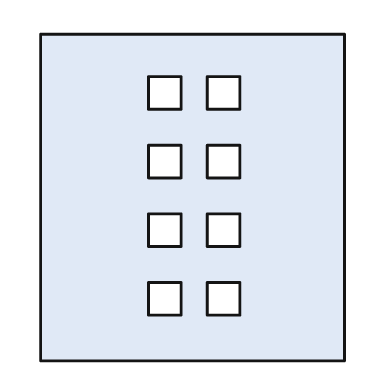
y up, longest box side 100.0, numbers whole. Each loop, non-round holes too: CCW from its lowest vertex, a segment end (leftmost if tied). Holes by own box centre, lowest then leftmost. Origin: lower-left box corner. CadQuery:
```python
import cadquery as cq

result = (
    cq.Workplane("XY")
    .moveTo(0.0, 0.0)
    .lineTo(93.0, 0.0)
    .lineTo(93.0, 100.0)
    .lineTo(0.0, 100.0)
    .close()
    .moveTo(33.0, 14.0)
    .lineTo(43.0, 14.0)
    .lineTo(43.0, 24.0)
    .lineTo(33.0, 24.0)
    .close()
    .moveTo(51.0, 14.0)
    .lineTo(61.0, 14.0)
    .lineTo(61.0, 24.0)
    .lineTo(51.0, 24.0)
    .close()
    .moveTo(33.0, 35.0)
    .lineTo(43.0, 35.0)
    .lineTo(43.0, 45.0)
    .lineTo(33.0, 45.0)
    .close()
    .moveTo(51.0, 35.0)
    .lineTo(61.0, 35.0)
    .lineTo(61.0, 45.0)
    .lineTo(51.0, 45.0)
    .close()
    .moveTo(33.0, 56.0)
    .lineTo(43.0, 56.0)
    .lineTo(43.0, 66.0)
    .lineTo(33.0, 66.0)
    .close()
    .moveTo(51.0, 56.0)
    .lineTo(61.0, 56.0)
    .lineTo(61.0, 66.0)
    .lineTo(51.0, 66.0)
    .close()
    .moveTo(33.0, 77.0)
    .lineTo(43.0, 77.0)
    .lineTo(43.0, 87.0)
    .lineTo(33.0, 87.0)
    .close()
    .moveTo(51.0, 77.0)
    .lineTo(61.0, 77.0)
    .lineTo(61.0, 87.0)
    .lineTo(51.0, 87.0)
    .close()
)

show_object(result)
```